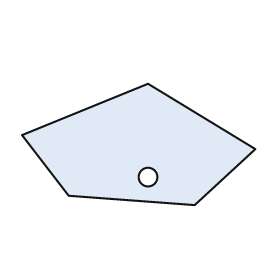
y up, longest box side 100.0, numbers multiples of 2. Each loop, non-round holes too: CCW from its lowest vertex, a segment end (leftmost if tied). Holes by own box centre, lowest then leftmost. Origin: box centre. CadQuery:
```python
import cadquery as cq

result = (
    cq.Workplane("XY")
    .moveTo(24.0, -26.0)
    .lineTo(50.0, -2.0)
    .lineTo(4.0, 26.0)
    .lineTo(-50.0, 4.0)
    .lineTo(-30.0, -22.0)
    .close()
    .moveTo(4.0, -14.0)
    .circle(4.0)
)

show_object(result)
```